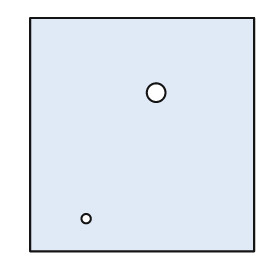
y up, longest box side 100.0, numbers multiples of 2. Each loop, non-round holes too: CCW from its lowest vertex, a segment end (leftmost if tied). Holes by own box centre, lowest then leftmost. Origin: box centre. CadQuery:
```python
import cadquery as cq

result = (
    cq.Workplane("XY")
    .moveTo(-48.0, -50.0)
    .lineTo(48.0, -50.0)
    .lineTo(48.0, 50.0)
    .lineTo(-48.0, 50.0)
    .close()
    .moveTo(-24.0, -36.0)
    .circle(2.0)
    .moveTo(6.0, 18.0)
    .circle(4.0)
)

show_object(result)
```